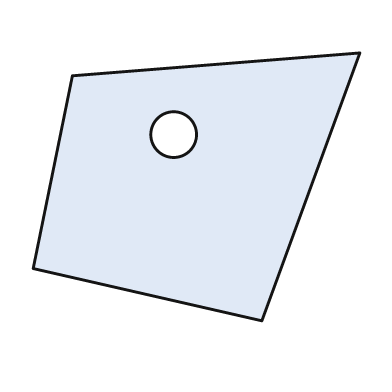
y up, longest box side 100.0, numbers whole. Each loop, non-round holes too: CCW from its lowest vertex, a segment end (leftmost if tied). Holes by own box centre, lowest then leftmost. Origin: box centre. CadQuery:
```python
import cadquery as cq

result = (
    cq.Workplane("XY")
    .moveTo(20.0, -41.0)
    .lineTo(50.0, 41.0)
    .lineTo(-38.0, 34.0)
    .lineTo(-50.0, -25.0)
    .close()
    .moveTo(-7.0, 16.0)
    .circle(7.0)
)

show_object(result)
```